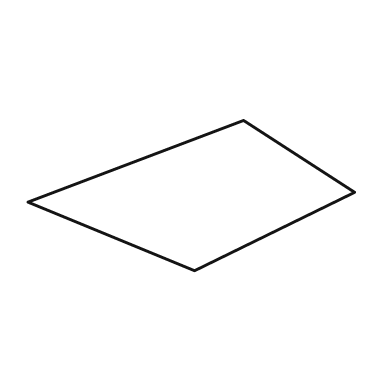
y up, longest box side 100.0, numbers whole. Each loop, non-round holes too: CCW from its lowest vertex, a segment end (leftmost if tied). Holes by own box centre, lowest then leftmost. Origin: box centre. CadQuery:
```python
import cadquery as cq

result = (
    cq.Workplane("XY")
    .moveTo(1.0, -23.0)
    .lineTo(50.0, 1.0)
    .lineTo(16.0, 23.0)
    .lineTo(-50.0, -2.0)
    .close()
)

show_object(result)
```